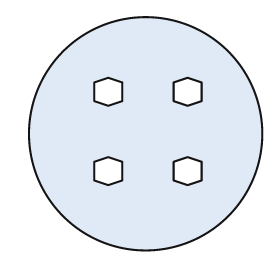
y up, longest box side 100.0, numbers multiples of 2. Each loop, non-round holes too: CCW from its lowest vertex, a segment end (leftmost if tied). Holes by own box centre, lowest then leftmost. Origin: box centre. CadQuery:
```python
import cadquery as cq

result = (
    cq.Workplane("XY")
    .moveTo(0.0, 0.0)
    .circle(50.0)
    .moveTo(-16.0, -22.0)
    .lineTo(-10.0, -20.0)
    .lineTo(-10.0, -12.0)
    .lineTo(-16.0, -10.0)
    .lineTo(-22.0, -12.0)
    .lineTo(-22.0, -20.0)
    .close()
    .moveTo(18.0, -22.0)
    .lineTo(24.0, -20.0)
    .lineTo(24.0, -12.0)
    .lineTo(18.0, -10.0)
    .lineTo(12.0, -12.0)
    .lineTo(12.0, -20.0)
    .close()
    .moveTo(-16.0, 12.0)
    .lineTo(-10.0, 14.0)
    .lineTo(-10.0, 22.0)
    .lineTo(-16.0, 24.0)
    .lineTo(-22.0, 22.0)
    .lineTo(-22.0, 14.0)
    .close()
    .moveTo(18.0, 12.0)
    .lineTo(24.0, 14.0)
    .lineTo(24.0, 22.0)
    .lineTo(18.0, 24.0)
    .lineTo(12.0, 22.0)
    .lineTo(12.0, 14.0)
    .close()
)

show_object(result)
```